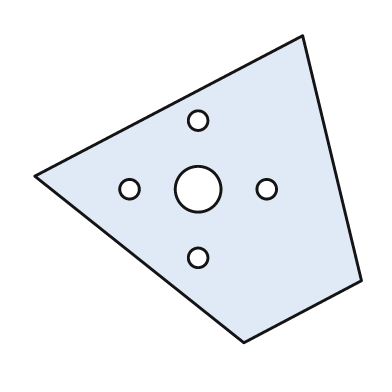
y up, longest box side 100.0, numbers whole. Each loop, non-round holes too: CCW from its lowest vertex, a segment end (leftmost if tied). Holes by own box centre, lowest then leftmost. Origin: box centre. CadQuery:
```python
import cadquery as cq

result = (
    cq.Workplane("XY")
    .moveTo(14.0, -47.0)
    .lineTo(50.0, -28.0)
    .lineTo(32.0, 47.0)
    .lineTo(-50.0, 4.0)
    .close()
    .moveTo(0.0, -21.0)
    .circle(3.0)
    .moveTo(-21.0, 0.0)
    .circle(3.0)
    .moveTo(0.0, 0.0)
    .circle(7.0)
    .moveTo(21.0, 0.0)
    .circle(3.0)
    .moveTo(0.0, 21.0)
    .circle(3.0)
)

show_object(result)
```